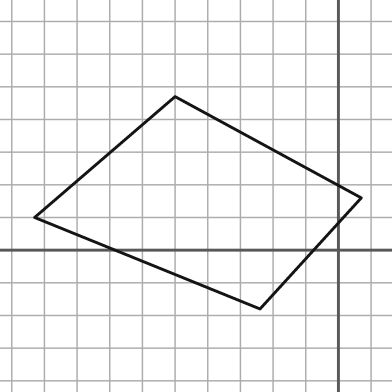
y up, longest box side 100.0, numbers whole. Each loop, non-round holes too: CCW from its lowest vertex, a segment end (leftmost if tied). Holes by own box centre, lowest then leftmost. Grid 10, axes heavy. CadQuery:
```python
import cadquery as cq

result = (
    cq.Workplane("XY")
    .moveTo(-24.0, -18.0)
    .lineTo(7.0, 16.0)
    .lineTo(-50.0, 47.0)
    .lineTo(-93.0, 10.0)
    .close()
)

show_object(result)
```